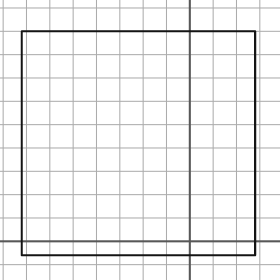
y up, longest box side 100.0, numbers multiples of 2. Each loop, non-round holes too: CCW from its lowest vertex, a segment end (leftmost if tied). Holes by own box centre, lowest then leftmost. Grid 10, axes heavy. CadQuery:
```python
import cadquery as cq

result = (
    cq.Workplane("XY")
    .moveTo(-72.0, -6.0)
    .lineTo(28.0, -6.0)
    .lineTo(28.0, 90.0)
    .lineTo(-72.0, 90.0)
    .close()
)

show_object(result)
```